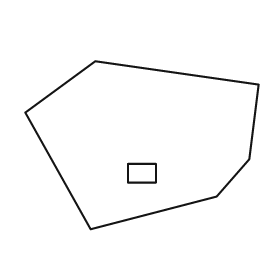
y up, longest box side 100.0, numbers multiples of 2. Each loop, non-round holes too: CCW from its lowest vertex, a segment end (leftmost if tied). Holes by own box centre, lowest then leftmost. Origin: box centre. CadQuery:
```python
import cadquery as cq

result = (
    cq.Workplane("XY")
    .moveTo(-22.0, -36.0)
    .lineTo(32.0, -22.0)
    .lineTo(46.0, -6.0)
    .lineTo(50.0, 26.0)
    .lineTo(-20.0, 36.0)
    .lineTo(-50.0, 14.0)
    .close()
    .moveTo(-6.0, -16.0)
    .lineTo(6.0, -16.0)
    .lineTo(6.0, -8.0)
    .lineTo(-6.0, -8.0)
    .close()
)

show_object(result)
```